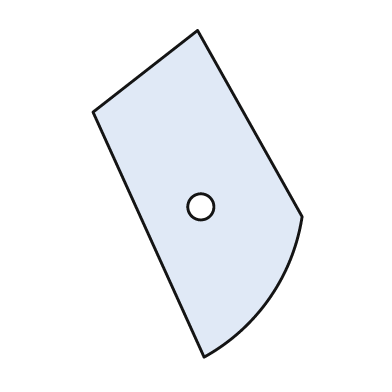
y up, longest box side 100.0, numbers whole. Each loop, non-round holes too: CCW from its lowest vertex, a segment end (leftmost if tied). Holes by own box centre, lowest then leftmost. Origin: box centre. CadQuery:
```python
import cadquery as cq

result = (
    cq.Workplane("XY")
    .moveTo(2.0, -50.0)
    .threePointArc((22.0, -32.0), (32.0, -7.0))
    .lineTo(0.0, 50.0)
    .lineTo(-32.0, 25.0)
    .close()
    .moveTo(1.0, -4.0)
    .circle(4.0)
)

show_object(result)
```